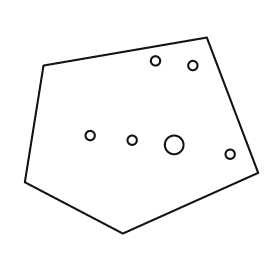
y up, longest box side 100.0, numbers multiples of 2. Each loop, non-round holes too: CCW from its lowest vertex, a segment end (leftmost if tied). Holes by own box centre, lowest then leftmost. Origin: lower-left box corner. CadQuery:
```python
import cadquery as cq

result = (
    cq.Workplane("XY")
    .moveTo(42.0, 0.0)
    .lineTo(100.0, 26.0)
    .lineTo(78.0, 84.0)
    .lineTo(8.0, 72.0)
    .lineTo(0.0, 22.0)
    .close()
    .moveTo(88.0, 34.0)
    .circle(2.0)
    .moveTo(64.0, 38.0)
    .circle(4.0)
    .moveTo(46.0, 40.0)
    .circle(2.0)
    .moveTo(28.0, 42.0)
    .circle(2.0)
    .moveTo(72.0, 72.0)
    .circle(2.0)
    .moveTo(56.0, 74.0)
    .circle(2.0)
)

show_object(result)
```